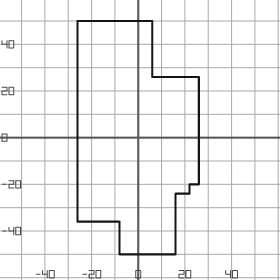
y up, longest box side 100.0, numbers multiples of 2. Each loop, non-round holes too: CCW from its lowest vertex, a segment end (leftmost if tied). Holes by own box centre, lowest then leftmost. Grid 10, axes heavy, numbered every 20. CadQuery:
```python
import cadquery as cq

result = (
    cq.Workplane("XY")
    .moveTo(-8.0, -50.0)
    .lineTo(16.0, -50.0)
    .lineTo(16.0, -24.0)
    .lineTo(22.0, -24.0)
    .lineTo(22.0, -20.0)
    .lineTo(26.0, -20.0)
    .lineTo(26.0, 26.0)
    .lineTo(6.0, 26.0)
    .lineTo(6.0, 50.0)
    .lineTo(-26.0, 50.0)
    .lineTo(-26.0, -36.0)
    .lineTo(-8.0, -36.0)
    .close()
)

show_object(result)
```